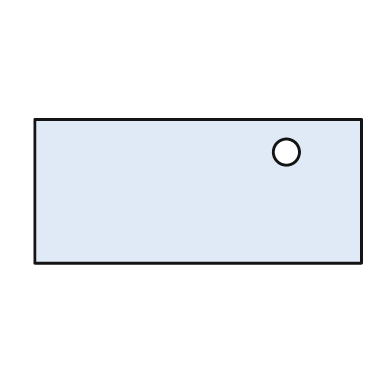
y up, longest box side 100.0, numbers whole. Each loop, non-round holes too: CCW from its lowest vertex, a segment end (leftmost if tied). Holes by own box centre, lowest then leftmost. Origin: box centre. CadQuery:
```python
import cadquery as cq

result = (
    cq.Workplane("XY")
    .moveTo(-50.0, -22.0)
    .lineTo(50.0, -22.0)
    .lineTo(50.0, 22.0)
    .lineTo(-50.0, 22.0)
    .close()
    .moveTo(27.0, 12.0)
    .circle(4.0)
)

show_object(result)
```